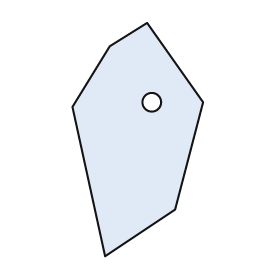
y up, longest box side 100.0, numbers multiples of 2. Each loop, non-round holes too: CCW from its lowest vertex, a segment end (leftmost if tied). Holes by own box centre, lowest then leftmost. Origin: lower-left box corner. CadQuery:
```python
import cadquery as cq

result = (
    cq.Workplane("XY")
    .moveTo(14.0, 0.0)
    .lineTo(44.0, 20.0)
    .lineTo(56.0, 66.0)
    .lineTo(32.0, 100.0)
    .lineTo(16.0, 90.0)
    .lineTo(0.0, 64.0)
    .close()
    .moveTo(34.0, 66.0)
    .circle(4.0)
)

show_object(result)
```